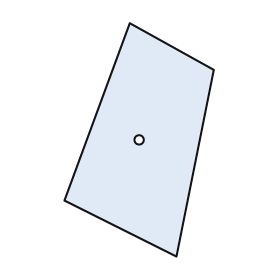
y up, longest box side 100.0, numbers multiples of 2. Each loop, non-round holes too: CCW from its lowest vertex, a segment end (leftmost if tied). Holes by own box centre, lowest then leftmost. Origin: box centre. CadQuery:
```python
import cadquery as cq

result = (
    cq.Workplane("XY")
    .moveTo(16.0, -50.0)
    .lineTo(32.0, 30.0)
    .lineTo(-4.0, 50.0)
    .lineTo(-32.0, -26.0)
    .close()
    .moveTo(0.0, 0.0)
    .circle(2.0)
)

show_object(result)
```